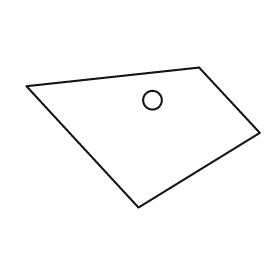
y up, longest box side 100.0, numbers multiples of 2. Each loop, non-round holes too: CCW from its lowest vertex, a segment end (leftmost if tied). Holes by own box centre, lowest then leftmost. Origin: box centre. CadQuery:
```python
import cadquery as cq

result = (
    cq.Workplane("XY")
    .moveTo(-2.0, -30.0)
    .lineTo(50.0, 2.0)
    .lineTo(24.0, 30.0)
    .lineTo(-50.0, 22.0)
    .close()
    .moveTo(4.0, 16.0)
    .circle(4.0)
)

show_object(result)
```